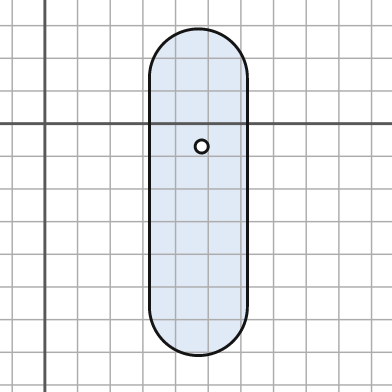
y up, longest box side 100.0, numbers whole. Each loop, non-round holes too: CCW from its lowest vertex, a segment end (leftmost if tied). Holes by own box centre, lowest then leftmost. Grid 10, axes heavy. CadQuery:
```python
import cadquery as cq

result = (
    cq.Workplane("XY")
    .moveTo(32.0, -56.0)
    .threePointArc((47.0, -71.0), (62.0, -56.0))
    .lineTo(62.0, 14.0)
    .threePointArc((47.0, 29.0), (32.0, 14.0))
    .close()
    .moveTo(48.0, -7.0)
    .circle(2.0)
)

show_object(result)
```